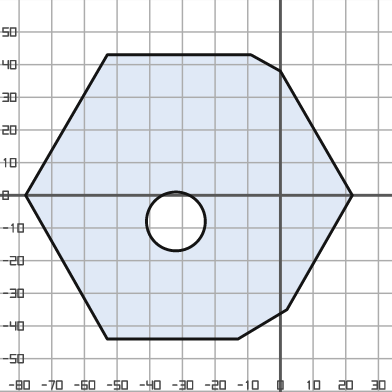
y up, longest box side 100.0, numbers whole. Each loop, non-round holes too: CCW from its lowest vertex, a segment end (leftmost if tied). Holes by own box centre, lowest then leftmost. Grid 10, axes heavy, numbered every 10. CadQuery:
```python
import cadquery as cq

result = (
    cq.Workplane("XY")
    .moveTo(-53.0, -44.0)
    .lineTo(-13.0, -44.0)
    .lineTo(2.0, -35.0)
    .lineTo(22.0, 0.0)
    .lineTo(0.0, 38.0)
    .lineTo(-9.0, 43.0)
    .lineTo(-53.0, 43.0)
    .lineTo(-78.0, 0.0)
    .close()
    .moveTo(-32.0, -8.0)
    .circle(9.0)
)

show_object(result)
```